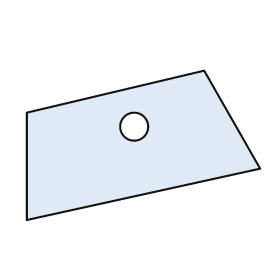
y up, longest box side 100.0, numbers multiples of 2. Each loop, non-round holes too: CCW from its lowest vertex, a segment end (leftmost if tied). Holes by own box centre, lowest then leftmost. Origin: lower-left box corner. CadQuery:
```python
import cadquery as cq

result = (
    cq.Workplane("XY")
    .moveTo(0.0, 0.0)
    .lineTo(100.0, 22.0)
    .lineTo(76.0, 64.0)
    .lineTo(0.0, 46.0)
    .close()
    .moveTo(46.0, 40.0)
    .circle(6.0)
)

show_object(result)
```